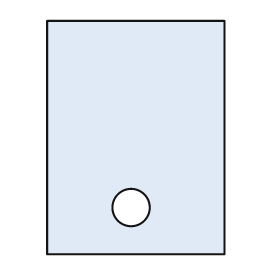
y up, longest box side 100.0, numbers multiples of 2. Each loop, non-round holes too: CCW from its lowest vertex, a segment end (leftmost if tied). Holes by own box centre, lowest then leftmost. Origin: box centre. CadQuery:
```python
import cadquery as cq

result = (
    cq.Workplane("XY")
    .moveTo(-38.0, -50.0)
    .lineTo(38.0, -50.0)
    .lineTo(38.0, 50.0)
    .lineTo(-38.0, 50.0)
    .close()
    .moveTo(-2.0, -30.0)
    .circle(8.0)
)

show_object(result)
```